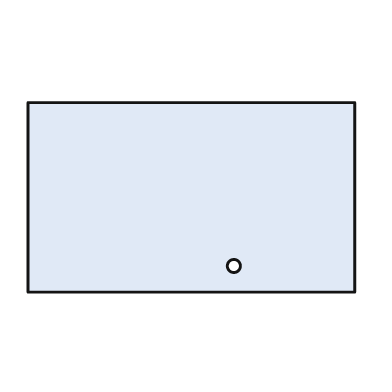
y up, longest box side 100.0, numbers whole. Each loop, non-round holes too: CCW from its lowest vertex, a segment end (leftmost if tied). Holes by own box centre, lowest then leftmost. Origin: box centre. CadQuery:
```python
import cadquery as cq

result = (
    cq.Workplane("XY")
    .moveTo(-50.0, -29.0)
    .lineTo(50.0, -29.0)
    .lineTo(50.0, 29.0)
    .lineTo(-50.0, 29.0)
    .close()
    .moveTo(13.0, -21.0)
    .circle(2.0)
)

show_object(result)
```